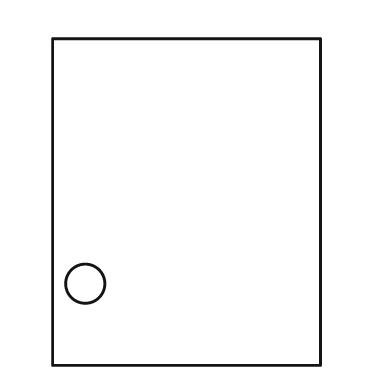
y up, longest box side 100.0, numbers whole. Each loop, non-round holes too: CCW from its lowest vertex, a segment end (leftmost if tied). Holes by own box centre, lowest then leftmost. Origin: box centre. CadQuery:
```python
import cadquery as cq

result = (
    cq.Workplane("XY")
    .moveTo(-41.0, -50.0)
    .lineTo(41.0, -50.0)
    .lineTo(41.0, 50.0)
    .lineTo(-41.0, 50.0)
    .close()
    .moveTo(-31.0, -25.0)
    .circle(6.0)
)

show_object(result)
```